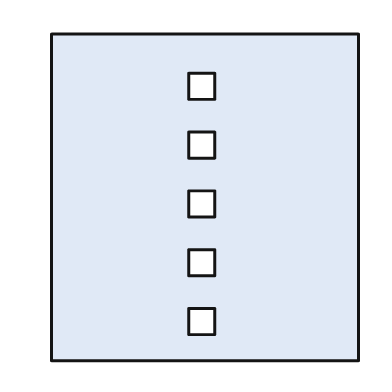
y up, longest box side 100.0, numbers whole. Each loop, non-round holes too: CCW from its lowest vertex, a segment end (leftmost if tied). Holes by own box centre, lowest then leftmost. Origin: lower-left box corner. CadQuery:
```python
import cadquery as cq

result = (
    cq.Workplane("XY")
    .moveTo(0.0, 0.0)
    .lineTo(94.0, 0.0)
    .lineTo(94.0, 100.0)
    .lineTo(0.0, 100.0)
    .close()
    .moveTo(42.0, 8.0)
    .lineTo(50.0, 8.0)
    .lineTo(50.0, 16.0)
    .lineTo(42.0, 16.0)
    .close()
    .moveTo(42.0, 26.0)
    .lineTo(50.0, 26.0)
    .lineTo(50.0, 34.0)
    .lineTo(42.0, 34.0)
    .close()
    .moveTo(42.0, 44.0)
    .lineTo(50.0, 44.0)
    .lineTo(50.0, 52.0)
    .lineTo(42.0, 52.0)
    .close()
    .moveTo(42.0, 62.0)
    .lineTo(50.0, 62.0)
    .lineTo(50.0, 70.0)
    .lineTo(42.0, 70.0)
    .close()
    .moveTo(42.0, 80.0)
    .lineTo(50.0, 80.0)
    .lineTo(50.0, 88.0)
    .lineTo(42.0, 88.0)
    .close()
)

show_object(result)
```